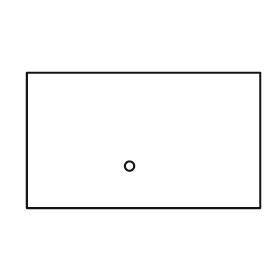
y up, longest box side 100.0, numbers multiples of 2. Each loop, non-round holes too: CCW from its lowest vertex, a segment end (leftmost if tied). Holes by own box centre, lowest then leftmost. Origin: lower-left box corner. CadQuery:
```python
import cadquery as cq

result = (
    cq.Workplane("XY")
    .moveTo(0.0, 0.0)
    .lineTo(100.0, 0.0)
    .lineTo(100.0, 58.0)
    .lineTo(0.0, 58.0)
    .close()
    .moveTo(44.0, 18.0)
    .circle(2.0)
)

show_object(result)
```